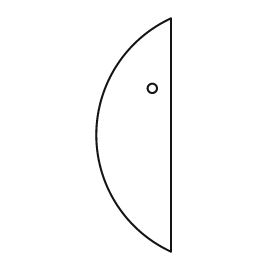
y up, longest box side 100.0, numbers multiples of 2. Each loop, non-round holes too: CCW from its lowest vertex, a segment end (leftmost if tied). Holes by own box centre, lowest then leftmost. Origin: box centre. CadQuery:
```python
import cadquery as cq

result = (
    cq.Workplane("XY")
    .moveTo(16.0, -50.0)
    .lineTo(16.0, 50.0)
    .threePointArc((-16.0, 0.0), (16.0, -50.0))
    .close()
    .moveTo(8.0, 20.0)
    .circle(2.0)
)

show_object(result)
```